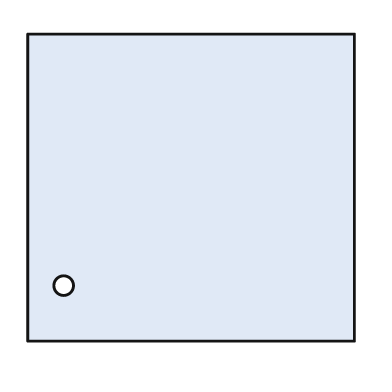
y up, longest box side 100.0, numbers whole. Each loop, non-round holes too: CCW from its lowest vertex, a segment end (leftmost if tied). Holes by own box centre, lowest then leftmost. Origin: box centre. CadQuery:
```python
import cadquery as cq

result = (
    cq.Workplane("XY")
    .moveTo(-50.0, -47.0)
    .lineTo(50.0, -47.0)
    .lineTo(50.0, 47.0)
    .lineTo(-50.0, 47.0)
    .close()
    .moveTo(-39.0, -30.0)
    .circle(3.0)
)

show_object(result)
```